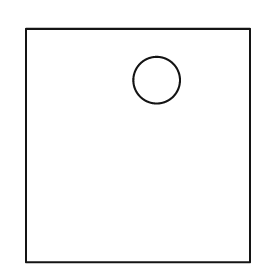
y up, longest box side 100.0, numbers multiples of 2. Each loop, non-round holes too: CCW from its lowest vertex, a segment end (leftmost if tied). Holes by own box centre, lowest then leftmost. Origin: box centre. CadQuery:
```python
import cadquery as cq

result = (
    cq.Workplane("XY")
    .moveTo(-48.0, -50.0)
    .lineTo(48.0, -50.0)
    .lineTo(48.0, 50.0)
    .lineTo(-48.0, 50.0)
    .close()
    .moveTo(8.0, 28.0)
    .circle(10.0)
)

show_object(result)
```